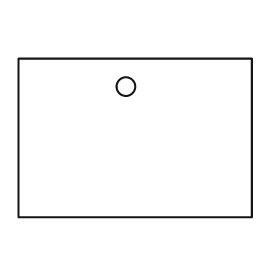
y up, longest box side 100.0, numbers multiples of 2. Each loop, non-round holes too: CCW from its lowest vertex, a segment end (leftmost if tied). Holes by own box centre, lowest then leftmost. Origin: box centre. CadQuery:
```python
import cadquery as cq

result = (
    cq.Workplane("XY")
    .moveTo(-50.0, -34.0)
    .lineTo(50.0, -34.0)
    .lineTo(50.0, 34.0)
    .lineTo(-50.0, 34.0)
    .close()
    .moveTo(-4.0, 22.0)
    .circle(4.0)
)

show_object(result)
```